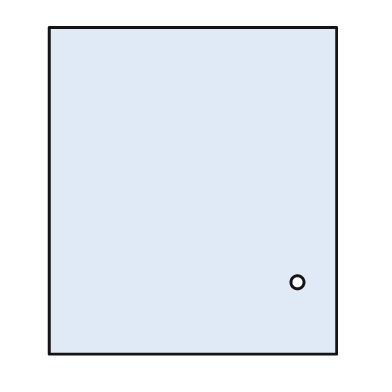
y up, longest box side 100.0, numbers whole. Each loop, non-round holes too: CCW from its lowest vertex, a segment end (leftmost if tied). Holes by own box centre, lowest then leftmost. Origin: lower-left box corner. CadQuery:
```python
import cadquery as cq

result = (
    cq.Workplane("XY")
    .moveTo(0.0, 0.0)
    .lineTo(88.0, 0.0)
    .lineTo(88.0, 100.0)
    .lineTo(0.0, 100.0)
    .close()
    .moveTo(76.0, 22.0)
    .circle(2.0)
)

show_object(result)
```